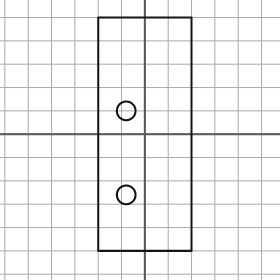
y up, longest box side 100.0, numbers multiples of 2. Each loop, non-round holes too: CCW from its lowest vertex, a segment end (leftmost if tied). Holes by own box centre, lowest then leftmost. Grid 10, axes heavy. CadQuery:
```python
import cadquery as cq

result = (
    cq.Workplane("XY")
    .moveTo(-20.0, -50.0)
    .lineTo(20.0, -50.0)
    .lineTo(20.0, 50.0)
    .lineTo(-20.0, 50.0)
    .close()
    .moveTo(-8.0, -26.0)
    .circle(4.0)
    .moveTo(-8.0, 10.0)
    .circle(4.0)
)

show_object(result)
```